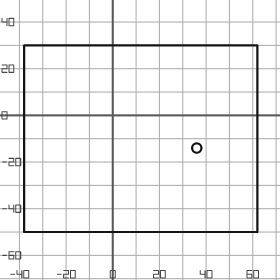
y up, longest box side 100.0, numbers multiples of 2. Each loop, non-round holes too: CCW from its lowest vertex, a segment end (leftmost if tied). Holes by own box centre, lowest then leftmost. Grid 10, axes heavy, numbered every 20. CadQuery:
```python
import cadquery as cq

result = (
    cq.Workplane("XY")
    .moveTo(-38.0, -50.0)
    .lineTo(62.0, -50.0)
    .lineTo(62.0, 30.0)
    .lineTo(-38.0, 30.0)
    .close()
    .moveTo(36.0, -14.0)
    .circle(2.0)
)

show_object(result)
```